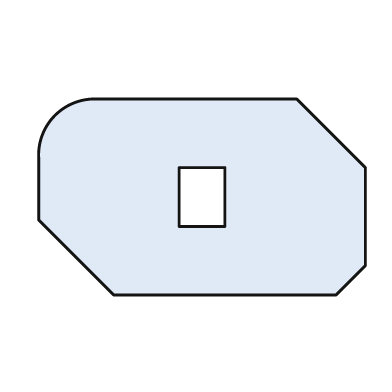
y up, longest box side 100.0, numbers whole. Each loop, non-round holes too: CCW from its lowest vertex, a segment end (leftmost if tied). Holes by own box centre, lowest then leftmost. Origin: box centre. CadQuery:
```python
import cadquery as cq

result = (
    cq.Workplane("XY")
    .moveTo(-27.0, -30.0)
    .lineTo(41.0, -30.0)
    .lineTo(50.0, -21.0)
    .lineTo(50.0, 9.0)
    .lineTo(29.0, 30.0)
    .lineTo(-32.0, 30.0)
    .threePointArc((-45.0, 25.0), (-50.0, 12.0))
    .lineTo(-50.0, -7.0)
    .close()
    .moveTo(-7.0, -9.0)
    .lineTo(7.0, -9.0)
    .lineTo(7.0, 9.0)
    .lineTo(-7.0, 9.0)
    .close()
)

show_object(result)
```